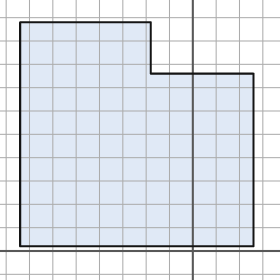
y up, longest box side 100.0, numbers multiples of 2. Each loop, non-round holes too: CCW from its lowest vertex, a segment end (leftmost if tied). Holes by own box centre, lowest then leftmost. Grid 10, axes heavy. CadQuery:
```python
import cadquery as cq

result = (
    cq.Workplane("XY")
    .moveTo(-74.0, 2.0)
    .lineTo(26.0, 2.0)
    .lineTo(26.0, 76.0)
    .lineTo(-18.0, 76.0)
    .lineTo(-18.0, 98.0)
    .lineTo(-74.0, 98.0)
    .close()
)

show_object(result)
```